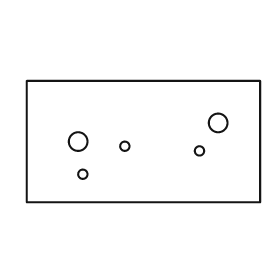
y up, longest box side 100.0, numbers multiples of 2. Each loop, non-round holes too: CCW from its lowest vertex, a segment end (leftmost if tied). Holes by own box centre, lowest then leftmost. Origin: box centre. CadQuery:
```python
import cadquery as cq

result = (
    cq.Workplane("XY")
    .moveTo(-50.0, -26.0)
    .lineTo(50.0, -26.0)
    .lineTo(50.0, 26.0)
    .lineTo(-50.0, 26.0)
    .close()
    .moveTo(-26.0, -14.0)
    .circle(2.0)
    .moveTo(24.0, -4.0)
    .circle(2.0)
    .moveTo(-8.0, -2.0)
    .circle(2.0)
    .moveTo(-28.0, 0.0)
    .circle(4.0)
    .moveTo(32.0, 8.0)
    .circle(4.0)
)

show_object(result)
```